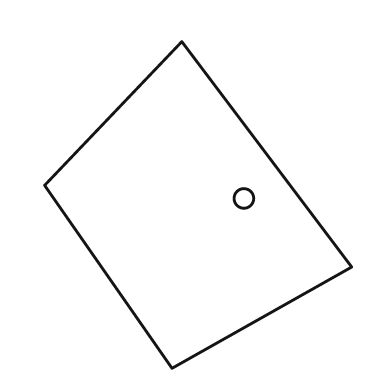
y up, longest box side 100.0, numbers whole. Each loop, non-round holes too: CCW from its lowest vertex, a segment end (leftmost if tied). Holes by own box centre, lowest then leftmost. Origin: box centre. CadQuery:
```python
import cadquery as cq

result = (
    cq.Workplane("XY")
    .moveTo(-8.0, -50.0)
    .lineTo(47.0, -19.0)
    .lineTo(-5.0, 50.0)
    .lineTo(-47.0, 6.0)
    .close()
    .moveTo(14.0, 2.0)
    .circle(3.0)
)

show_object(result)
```